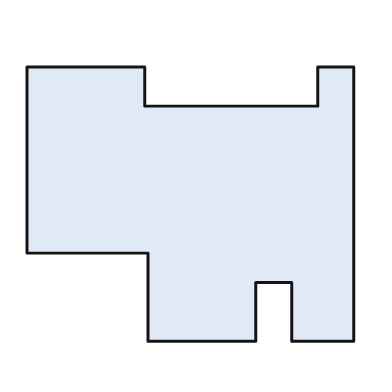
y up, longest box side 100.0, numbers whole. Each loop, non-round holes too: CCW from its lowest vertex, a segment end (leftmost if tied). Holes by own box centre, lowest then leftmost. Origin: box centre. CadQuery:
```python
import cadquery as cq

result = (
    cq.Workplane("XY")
    .moveTo(-13.0, -42.0)
    .lineTo(20.0, -42.0)
    .lineTo(20.0, -24.0)
    .lineTo(31.0, -24.0)
    .lineTo(31.0, -42.0)
    .lineTo(50.0, -42.0)
    .lineTo(50.0, 42.0)
    .lineTo(39.0, 42.0)
    .lineTo(39.0, 30.0)
    .lineTo(-14.0, 30.0)
    .lineTo(-14.0, 42.0)
    .lineTo(-50.0, 42.0)
    .lineTo(-50.0, -15.0)
    .lineTo(-13.0, -15.0)
    .close()
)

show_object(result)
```